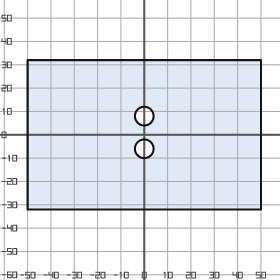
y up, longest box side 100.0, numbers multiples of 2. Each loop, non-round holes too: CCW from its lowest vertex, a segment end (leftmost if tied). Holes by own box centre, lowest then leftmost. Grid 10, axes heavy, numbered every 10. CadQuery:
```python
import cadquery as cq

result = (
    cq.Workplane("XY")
    .moveTo(-50.0, -32.0)
    .lineTo(50.0, -32.0)
    .lineTo(50.0, 32.0)
    .lineTo(-50.0, 32.0)
    .close()
    .moveTo(0.0, -6.0)
    .circle(4.0)
    .moveTo(0.0, 8.0)
    .circle(4.0)
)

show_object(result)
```